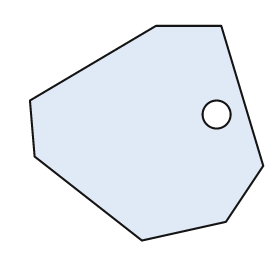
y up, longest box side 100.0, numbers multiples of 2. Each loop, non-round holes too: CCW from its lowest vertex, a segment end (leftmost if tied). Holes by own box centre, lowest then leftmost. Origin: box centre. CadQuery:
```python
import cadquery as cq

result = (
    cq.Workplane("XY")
    .moveTo(-2.0, -46.0)
    .lineTo(34.0, -38.0)
    .lineTo(50.0, -14.0)
    .lineTo(32.0, 46.0)
    .lineTo(4.0, 46.0)
    .lineTo(-50.0, 14.0)
    .lineTo(-48.0, -10.0)
    .close()
    .moveTo(30.0, 8.0)
    .circle(6.0)
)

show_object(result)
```